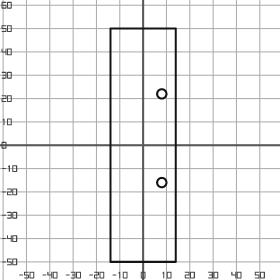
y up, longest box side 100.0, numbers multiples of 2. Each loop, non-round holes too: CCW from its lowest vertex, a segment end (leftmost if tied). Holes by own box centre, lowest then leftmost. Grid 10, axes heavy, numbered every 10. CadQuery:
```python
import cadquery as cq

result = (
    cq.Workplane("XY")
    .moveTo(-14.0, -50.0)
    .lineTo(14.0, -50.0)
    .lineTo(14.0, 50.0)
    .lineTo(-14.0, 50.0)
    .close()
    .moveTo(8.0, -16.0)
    .circle(2.0)
    .moveTo(8.0, 22.0)
    .circle(2.0)
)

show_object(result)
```